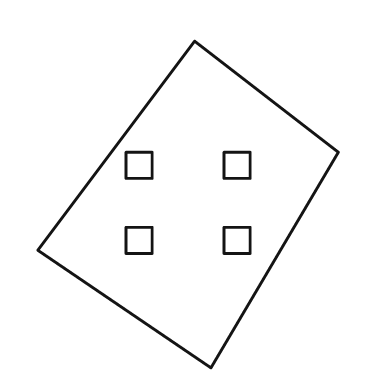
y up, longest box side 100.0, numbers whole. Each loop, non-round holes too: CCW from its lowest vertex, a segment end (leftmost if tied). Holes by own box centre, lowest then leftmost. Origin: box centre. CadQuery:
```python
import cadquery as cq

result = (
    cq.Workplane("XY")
    .moveTo(7.0, -50.0)
    .lineTo(46.0, 16.0)
    .lineTo(2.0, 50.0)
    .lineTo(-46.0, -14.0)
    .close()
    .moveTo(-19.0, -15.0)
    .lineTo(-11.0, -15.0)
    .lineTo(-11.0, -7.0)
    .lineTo(-19.0, -7.0)
    .close()
    .moveTo(11.0, -15.0)
    .lineTo(19.0, -15.0)
    .lineTo(19.0, -7.0)
    .lineTo(11.0, -7.0)
    .close()
    .moveTo(-19.0, 8.0)
    .lineTo(-11.0, 8.0)
    .lineTo(-11.0, 16.0)
    .lineTo(-19.0, 16.0)
    .close()
    .moveTo(11.0, 8.0)
    .lineTo(19.0, 8.0)
    .lineTo(19.0, 16.0)
    .lineTo(11.0, 16.0)
    .close()
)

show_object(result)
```